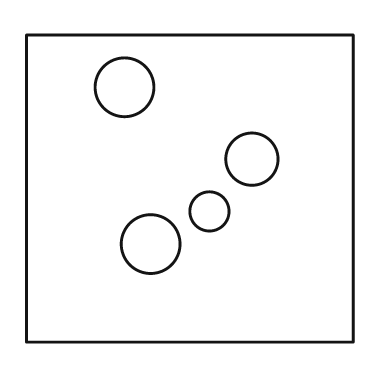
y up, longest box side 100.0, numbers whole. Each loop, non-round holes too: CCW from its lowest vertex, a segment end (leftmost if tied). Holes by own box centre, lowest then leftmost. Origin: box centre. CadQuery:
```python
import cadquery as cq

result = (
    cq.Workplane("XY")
    .moveTo(-50.0, -47.0)
    .lineTo(50.0, -47.0)
    .lineTo(50.0, 47.0)
    .lineTo(-50.0, 47.0)
    .close()
    .moveTo(-12.0, -17.0)
    .circle(9.0)
    .moveTo(6.0, -7.0)
    .circle(6.0)
    .moveTo(19.0, 9.0)
    .circle(8.0)
    .moveTo(-20.0, 31.0)
    .circle(9.0)
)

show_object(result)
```